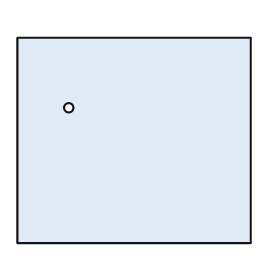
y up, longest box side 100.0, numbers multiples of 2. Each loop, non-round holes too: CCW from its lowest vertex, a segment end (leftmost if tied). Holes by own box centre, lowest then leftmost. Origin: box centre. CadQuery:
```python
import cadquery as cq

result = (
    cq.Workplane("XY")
    .moveTo(-50.0, -44.0)
    .lineTo(50.0, -44.0)
    .lineTo(50.0, 44.0)
    .lineTo(-50.0, 44.0)
    .close()
    .moveTo(-28.0, 14.0)
    .circle(2.0)
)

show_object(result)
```